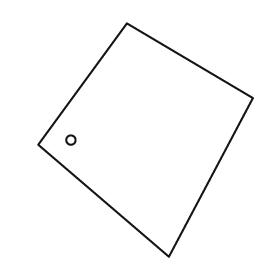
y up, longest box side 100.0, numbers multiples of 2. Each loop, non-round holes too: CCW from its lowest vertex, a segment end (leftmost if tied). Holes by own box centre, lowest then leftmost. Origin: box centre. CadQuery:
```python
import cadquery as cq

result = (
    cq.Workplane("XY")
    .moveTo(10.0, -50.0)
    .lineTo(46.0, 18.0)
    .lineTo(-8.0, 50.0)
    .lineTo(-46.0, -2.0)
    .close()
    .moveTo(-32.0, 0.0)
    .circle(2.0)
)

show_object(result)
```